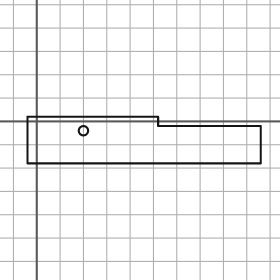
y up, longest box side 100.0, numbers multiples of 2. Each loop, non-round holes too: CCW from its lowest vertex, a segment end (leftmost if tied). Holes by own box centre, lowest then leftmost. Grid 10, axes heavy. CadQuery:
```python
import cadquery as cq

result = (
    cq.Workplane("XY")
    .moveTo(-4.0, -18.0)
    .lineTo(96.0, -18.0)
    .lineTo(96.0, -2.0)
    .lineTo(52.0, -2.0)
    .lineTo(52.0, 2.0)
    .lineTo(-4.0, 2.0)
    .close()
    .moveTo(20.0, -4.0)
    .circle(2.0)
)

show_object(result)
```